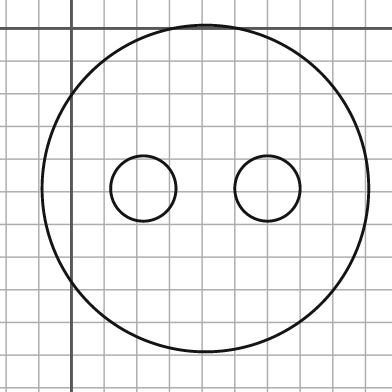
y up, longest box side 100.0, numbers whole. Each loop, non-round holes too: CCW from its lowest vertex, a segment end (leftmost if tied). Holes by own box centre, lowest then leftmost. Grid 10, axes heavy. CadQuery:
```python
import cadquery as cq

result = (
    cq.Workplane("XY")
    .moveTo(41.0, -49.0)
    .circle(50.0)
    .moveTo(22.0, -49.0)
    .circle(10.0)
    .moveTo(60.0, -49.0)
    .circle(10.0)
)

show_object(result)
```